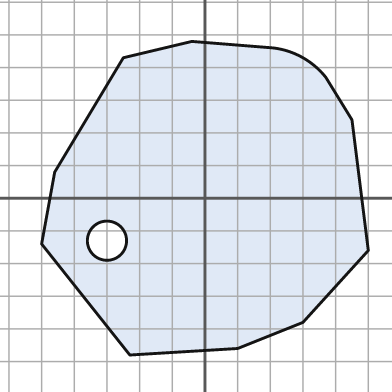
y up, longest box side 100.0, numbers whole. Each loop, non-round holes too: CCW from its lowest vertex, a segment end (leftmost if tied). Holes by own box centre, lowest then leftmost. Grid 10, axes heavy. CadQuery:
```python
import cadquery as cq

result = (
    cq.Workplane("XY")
    .moveTo(-23.0, -48.0)
    .lineTo(10.0, -46.0)
    .lineTo(30.0, -38.0)
    .lineTo(50.0, -16.0)
    .lineTo(45.0, 24.0)
    .lineTo(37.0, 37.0)
    .threePointArc((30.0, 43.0), (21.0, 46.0))
    .lineTo(-4.0, 48.0)
    .lineTo(-25.0, 43.0)
    .lineTo(-46.0, 8.0)
    .lineTo(-50.0, -14.0)
    .close()
    .moveTo(-30.0, -13.0)
    .circle(6.0)
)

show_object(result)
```